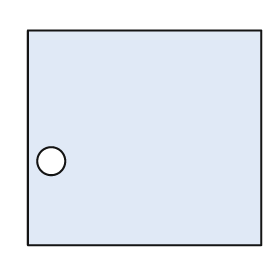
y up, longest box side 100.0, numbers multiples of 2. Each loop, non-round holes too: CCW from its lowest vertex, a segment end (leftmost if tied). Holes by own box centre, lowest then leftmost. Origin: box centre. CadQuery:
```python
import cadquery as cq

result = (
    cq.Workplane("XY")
    .moveTo(-50.0, -46.0)
    .lineTo(50.0, -46.0)
    .lineTo(50.0, 46.0)
    .lineTo(-50.0, 46.0)
    .close()
    .moveTo(-40.0, -10.0)
    .circle(6.0)
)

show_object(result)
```